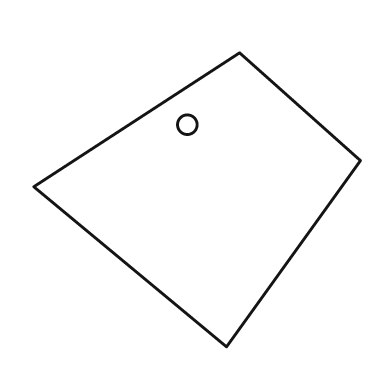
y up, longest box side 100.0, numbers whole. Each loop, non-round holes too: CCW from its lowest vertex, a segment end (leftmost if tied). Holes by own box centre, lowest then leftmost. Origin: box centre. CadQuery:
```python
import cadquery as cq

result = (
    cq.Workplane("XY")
    .moveTo(9.0, -45.0)
    .lineTo(50.0, 12.0)
    .lineTo(13.0, 45.0)
    .lineTo(-50.0, 4.0)
    .close()
    .moveTo(-3.0, 23.0)
    .circle(3.0)
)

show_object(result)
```